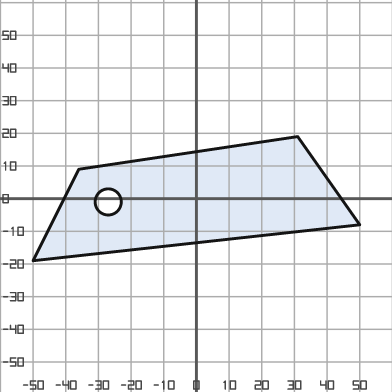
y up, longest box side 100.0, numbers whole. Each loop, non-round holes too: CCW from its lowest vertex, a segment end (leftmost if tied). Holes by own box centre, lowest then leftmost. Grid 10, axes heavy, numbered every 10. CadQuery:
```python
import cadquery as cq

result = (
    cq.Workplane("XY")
    .moveTo(-50.0, -19.0)
    .lineTo(50.0, -8.0)
    .lineTo(31.0, 19.0)
    .lineTo(-36.0, 9.0)
    .close()
    .moveTo(-27.0, -1.0)
    .circle(4.0)
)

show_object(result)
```